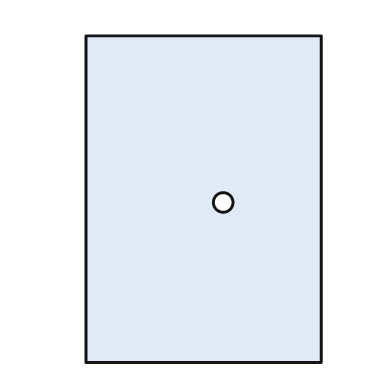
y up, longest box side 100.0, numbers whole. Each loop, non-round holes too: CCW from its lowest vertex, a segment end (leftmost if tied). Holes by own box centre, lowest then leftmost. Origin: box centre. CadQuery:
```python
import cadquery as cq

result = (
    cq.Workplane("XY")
    .moveTo(-36.0, -50.0)
    .lineTo(36.0, -50.0)
    .lineTo(36.0, 50.0)
    .lineTo(-36.0, 50.0)
    .close()
    .moveTo(6.0, -1.0)
    .circle(3.0)
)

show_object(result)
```